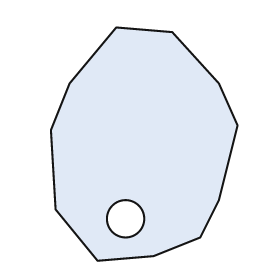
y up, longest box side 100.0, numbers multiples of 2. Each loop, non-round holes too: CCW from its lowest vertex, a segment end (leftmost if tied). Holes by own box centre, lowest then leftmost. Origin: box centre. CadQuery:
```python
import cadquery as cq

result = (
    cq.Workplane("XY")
    .moveTo(-20.0, -50.0)
    .lineTo(4.0, -48.0)
    .lineTo(24.0, -40.0)
    .lineTo(32.0, -24.0)
    .lineTo(40.0, 8.0)
    .lineTo(32.0, 26.0)
    .lineTo(12.0, 48.0)
    .lineTo(-12.0, 50.0)
    .lineTo(-32.0, 26.0)
    .lineTo(-40.0, 6.0)
    .lineTo(-38.0, -28.0)
    .close()
    .moveTo(-8.0, -32.0)
    .circle(8.0)
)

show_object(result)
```